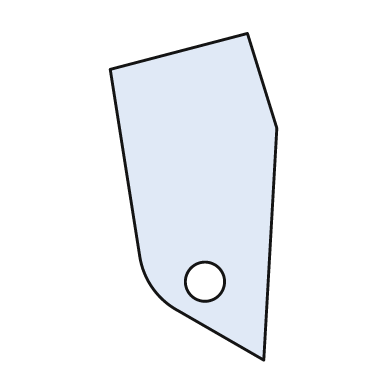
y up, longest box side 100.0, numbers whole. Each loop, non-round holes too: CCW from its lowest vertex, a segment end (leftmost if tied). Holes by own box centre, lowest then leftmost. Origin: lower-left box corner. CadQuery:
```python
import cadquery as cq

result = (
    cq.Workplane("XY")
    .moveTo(47.0, 0.0)
    .lineTo(51.0, 71.0)
    .lineTo(42.0, 100.0)
    .lineTo(0.0, 89.0)
    .lineTo(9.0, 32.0)
    .threePointArc((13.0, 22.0), (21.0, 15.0))
    .close()
    .moveTo(29.0, 24.0)
    .circle(6.0)
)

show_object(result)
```